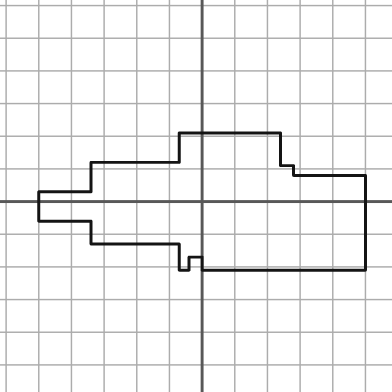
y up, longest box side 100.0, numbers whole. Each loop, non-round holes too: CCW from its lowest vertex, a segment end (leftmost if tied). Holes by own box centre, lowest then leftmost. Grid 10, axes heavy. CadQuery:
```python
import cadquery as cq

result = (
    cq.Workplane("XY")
    .moveTo(-7.0, -21.0)
    .lineTo(-4.0, -21.0)
    .lineTo(-4.0, -17.0)
    .lineTo(0.0, -17.0)
    .lineTo(0.0, -21.0)
    .lineTo(50.0, -21.0)
    .lineTo(50.0, 8.0)
    .lineTo(28.0, 8.0)
    .lineTo(28.0, 11.0)
    .lineTo(24.0, 11.0)
    .lineTo(24.0, 21.0)
    .lineTo(-7.0, 21.0)
    .lineTo(-7.0, 12.0)
    .lineTo(-34.0, 12.0)
    .lineTo(-34.0, 3.0)
    .lineTo(-50.0, 3.0)
    .lineTo(-50.0, -6.0)
    .lineTo(-34.0, -6.0)
    .lineTo(-34.0, -13.0)
    .lineTo(-7.0, -13.0)
    .close()
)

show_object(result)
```